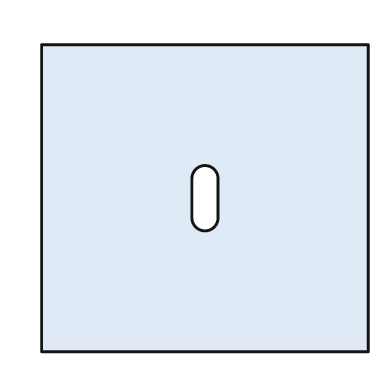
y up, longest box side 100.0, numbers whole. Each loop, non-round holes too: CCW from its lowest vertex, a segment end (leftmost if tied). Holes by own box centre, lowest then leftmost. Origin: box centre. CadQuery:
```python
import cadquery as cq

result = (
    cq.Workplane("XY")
    .moveTo(-50.0, -47.0)
    .lineTo(50.0, -47.0)
    .lineTo(50.0, 47.0)
    .lineTo(-50.0, 47.0)
    .close()
    .moveTo(-4.0, -6.0)
    .threePointArc((0.0, -10.0), (4.0, -6.0))
    .lineTo(4.0, 6.0)
    .threePointArc((0.0, 10.0), (-4.0, 6.0))
    .close()
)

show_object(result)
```